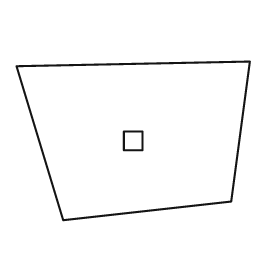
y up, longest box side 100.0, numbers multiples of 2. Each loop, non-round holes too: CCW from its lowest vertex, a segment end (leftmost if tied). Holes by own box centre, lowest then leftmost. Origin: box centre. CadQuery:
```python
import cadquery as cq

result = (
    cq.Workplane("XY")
    .moveTo(-30.0, -34.0)
    .lineTo(42.0, -26.0)
    .lineTo(50.0, 34.0)
    .lineTo(-50.0, 32.0)
    .close()
    .moveTo(-4.0, -4.0)
    .lineTo(4.0, -4.0)
    .lineTo(4.0, 4.0)
    .lineTo(-4.0, 4.0)
    .close()
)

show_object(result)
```